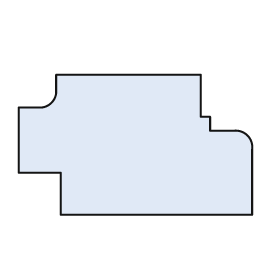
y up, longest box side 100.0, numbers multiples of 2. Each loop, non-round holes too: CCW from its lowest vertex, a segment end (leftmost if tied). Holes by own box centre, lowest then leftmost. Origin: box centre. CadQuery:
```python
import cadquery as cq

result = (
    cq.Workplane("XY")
    .moveTo(-32.0, -30.0)
    .lineTo(50.0, -30.0)
    .lineTo(50.0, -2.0)
    .threePointArc((48.0, 4.0), (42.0, 6.0))
    .lineTo(32.0, 6.0)
    .lineTo(32.0, 12.0)
    .lineTo(28.0, 12.0)
    .lineTo(28.0, 30.0)
    .lineTo(-34.0, 30.0)
    .lineTo(-34.0, 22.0)
    .threePointArc((-36.0, 18.0), (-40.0, 16.0))
    .lineTo(-50.0, 16.0)
    .lineTo(-50.0, -12.0)
    .lineTo(-32.0, -12.0)
    .close()
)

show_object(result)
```